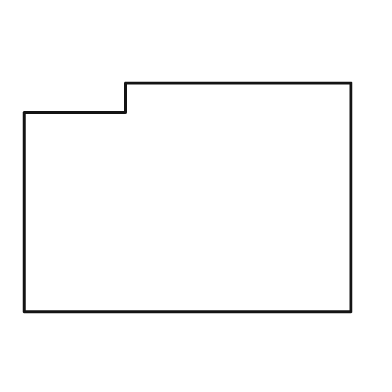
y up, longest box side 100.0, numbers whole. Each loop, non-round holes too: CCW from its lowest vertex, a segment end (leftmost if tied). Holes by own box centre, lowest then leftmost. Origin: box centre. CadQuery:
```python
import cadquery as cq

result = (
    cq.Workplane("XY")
    .moveTo(-50.0, -35.0)
    .lineTo(50.0, -35.0)
    .lineTo(50.0, 35.0)
    .lineTo(-19.0, 35.0)
    .lineTo(-19.0, 26.0)
    .lineTo(-50.0, 26.0)
    .close()
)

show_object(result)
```